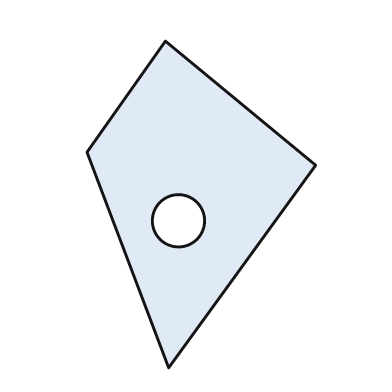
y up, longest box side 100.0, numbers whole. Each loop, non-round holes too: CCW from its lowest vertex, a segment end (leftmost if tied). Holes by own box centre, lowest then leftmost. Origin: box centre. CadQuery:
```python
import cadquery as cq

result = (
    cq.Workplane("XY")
    .moveTo(-10.0, -50.0)
    .lineTo(35.0, 12.0)
    .lineTo(-11.0, 50.0)
    .lineTo(-35.0, 16.0)
    .close()
    .moveTo(-7.0, -5.0)
    .circle(8.0)
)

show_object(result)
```